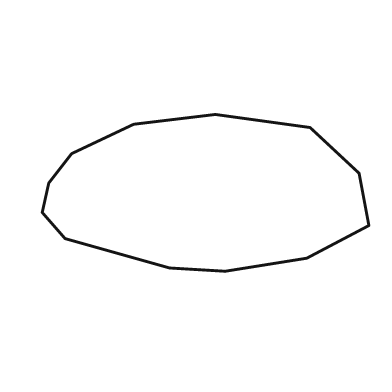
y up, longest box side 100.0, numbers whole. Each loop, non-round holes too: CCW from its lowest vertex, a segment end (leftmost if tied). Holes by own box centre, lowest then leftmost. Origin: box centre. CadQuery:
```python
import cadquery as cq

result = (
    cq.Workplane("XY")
    .moveTo(6.0, -24.0)
    .lineTo(31.0, -20.0)
    .lineTo(50.0, -10.0)
    .lineTo(47.0, 6.0)
    .lineTo(32.0, 20.0)
    .lineTo(3.0, 24.0)
    .lineTo(-22.0, 21.0)
    .lineTo(-41.0, 12.0)
    .lineTo(-48.0, 3.0)
    .lineTo(-50.0, -6.0)
    .lineTo(-43.0, -14.0)
    .lineTo(-11.0, -23.0)
    .close()
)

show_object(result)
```